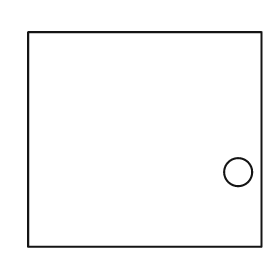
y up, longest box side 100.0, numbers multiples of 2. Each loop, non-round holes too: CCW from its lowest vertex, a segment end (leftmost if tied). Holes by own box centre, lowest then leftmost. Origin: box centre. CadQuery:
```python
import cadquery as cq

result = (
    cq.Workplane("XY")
    .moveTo(-50.0, -46.0)
    .lineTo(50.0, -46.0)
    .lineTo(50.0, 46.0)
    .lineTo(-50.0, 46.0)
    .close()
    .moveTo(40.0, -14.0)
    .circle(6.0)
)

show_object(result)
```